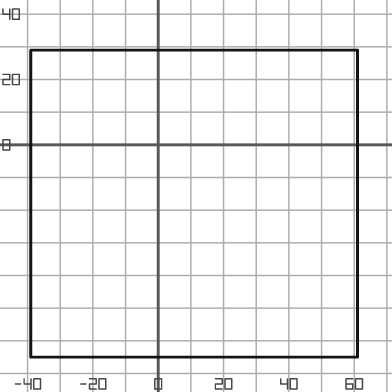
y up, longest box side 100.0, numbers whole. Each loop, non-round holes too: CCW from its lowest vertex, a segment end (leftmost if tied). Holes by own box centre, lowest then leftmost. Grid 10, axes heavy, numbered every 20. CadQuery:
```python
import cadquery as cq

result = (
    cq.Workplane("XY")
    .moveTo(-39.0, -65.0)
    .lineTo(61.0, -65.0)
    .lineTo(61.0, 29.0)
    .lineTo(-39.0, 29.0)
    .close()
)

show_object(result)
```